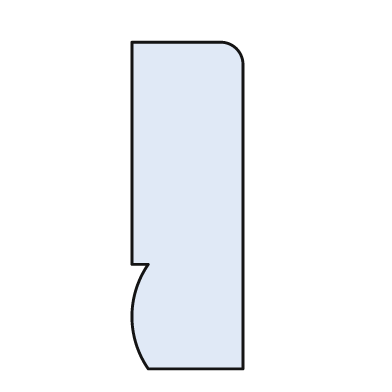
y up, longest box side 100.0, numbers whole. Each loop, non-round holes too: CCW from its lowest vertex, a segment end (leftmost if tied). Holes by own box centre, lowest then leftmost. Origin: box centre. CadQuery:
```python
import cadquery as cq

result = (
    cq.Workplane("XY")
    .moveTo(-12.0, -50.0)
    .lineTo(17.0, -50.0)
    .lineTo(17.0, 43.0)
    .threePointArc((15.0, 48.0), (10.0, 50.0))
    .lineTo(-17.0, 50.0)
    .lineTo(-17.0, -18.0)
    .lineTo(-12.0, -18.0)
    .threePointArc((-17.0, -34.0), (-12.0, -50.0))
    .close()
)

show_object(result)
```